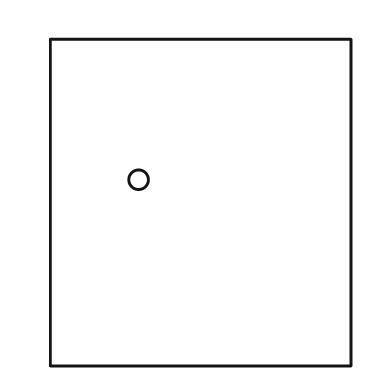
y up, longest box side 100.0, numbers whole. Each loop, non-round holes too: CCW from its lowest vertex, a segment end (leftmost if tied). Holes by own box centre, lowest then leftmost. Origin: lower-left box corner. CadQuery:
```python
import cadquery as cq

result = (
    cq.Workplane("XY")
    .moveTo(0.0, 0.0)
    .lineTo(92.0, 0.0)
    .lineTo(92.0, 100.0)
    .lineTo(0.0, 100.0)
    .close()
    .moveTo(27.0, 57.0)
    .circle(3.0)
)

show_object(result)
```